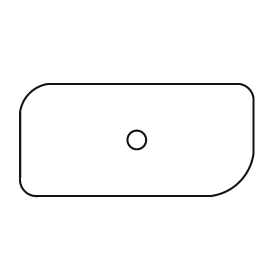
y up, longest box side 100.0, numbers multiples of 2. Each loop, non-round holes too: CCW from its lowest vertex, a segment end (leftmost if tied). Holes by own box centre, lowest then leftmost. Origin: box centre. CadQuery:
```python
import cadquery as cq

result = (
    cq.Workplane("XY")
    .moveTo(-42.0, -24.0)
    .lineTo(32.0, -24.0)
    .threePointArc((44.0, -18.0), (50.0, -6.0))
    .lineTo(50.0, 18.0)
    .threePointArc((48.0, 22.0), (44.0, 24.0))
    .lineTo(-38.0, 24.0)
    .threePointArc((-46.0, 20.0), (-50.0, 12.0))
    .lineTo(-50.0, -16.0)
    .threePointArc((-48.0, -22.0), (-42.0, -24.0))
    .close()
    .moveTo(0.0, 0.0)
    .circle(4.0)
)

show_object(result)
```